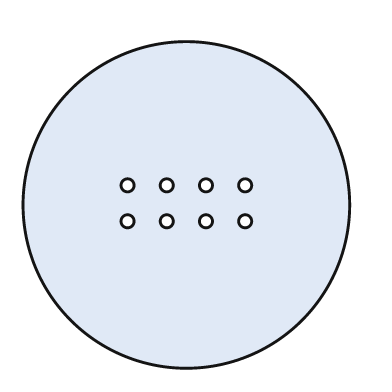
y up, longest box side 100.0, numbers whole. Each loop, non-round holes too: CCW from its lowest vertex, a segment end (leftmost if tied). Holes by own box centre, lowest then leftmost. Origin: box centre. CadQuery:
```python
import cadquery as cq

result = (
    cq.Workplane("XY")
    .moveTo(0.0, 0.0)
    .circle(50.0)
    .moveTo(-18.0, -5.0)
    .circle(2.0)
    .moveTo(-6.0, -5.0)
    .circle(2.0)
    .moveTo(6.0, -5.0)
    .circle(2.0)
    .moveTo(18.0, -5.0)
    .circle(2.0)
    .moveTo(-18.0, 6.0)
    .circle(2.0)
    .moveTo(-6.0, 6.0)
    .circle(2.0)
    .moveTo(6.0, 6.0)
    .circle(2.0)
    .moveTo(18.0, 6.0)
    .circle(2.0)
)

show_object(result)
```